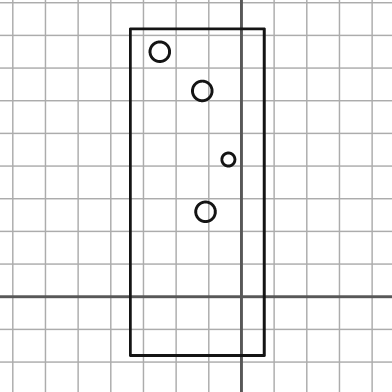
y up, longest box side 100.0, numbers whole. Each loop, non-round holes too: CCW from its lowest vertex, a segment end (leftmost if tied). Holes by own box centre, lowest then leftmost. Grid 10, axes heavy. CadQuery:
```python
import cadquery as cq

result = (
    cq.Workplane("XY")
    .moveTo(-34.0, -18.0)
    .lineTo(7.0, -18.0)
    .lineTo(7.0, 82.0)
    .lineTo(-34.0, 82.0)
    .close()
    .moveTo(-11.0, 26.0)
    .circle(3.0)
    .moveTo(-4.0, 42.0)
    .circle(2.0)
    .moveTo(-12.0, 63.0)
    .circle(3.0)
    .moveTo(-25.0, 75.0)
    .circle(3.0)
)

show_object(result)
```